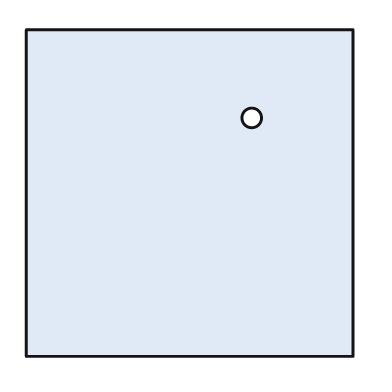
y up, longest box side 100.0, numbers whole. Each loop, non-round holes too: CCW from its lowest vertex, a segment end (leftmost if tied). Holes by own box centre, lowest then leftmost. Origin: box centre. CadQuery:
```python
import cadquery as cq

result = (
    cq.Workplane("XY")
    .moveTo(-50.0, -50.0)
    .lineTo(50.0, -50.0)
    .lineTo(50.0, 50.0)
    .lineTo(-50.0, 50.0)
    .close()
    .moveTo(19.0, 23.0)
    .circle(3.0)
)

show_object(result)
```